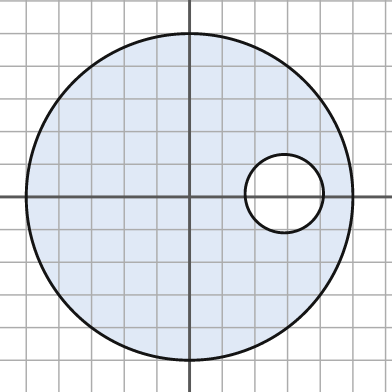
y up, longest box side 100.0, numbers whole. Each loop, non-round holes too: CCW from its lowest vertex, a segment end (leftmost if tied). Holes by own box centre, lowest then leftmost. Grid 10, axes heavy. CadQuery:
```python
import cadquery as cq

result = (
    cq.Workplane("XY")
    .moveTo(0.0, 0.0)
    .circle(50.0)
    .moveTo(29.0, 1.0)
    .circle(12.0)
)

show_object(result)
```